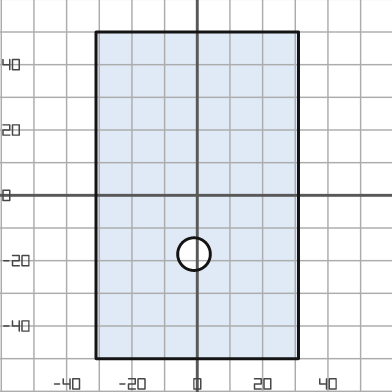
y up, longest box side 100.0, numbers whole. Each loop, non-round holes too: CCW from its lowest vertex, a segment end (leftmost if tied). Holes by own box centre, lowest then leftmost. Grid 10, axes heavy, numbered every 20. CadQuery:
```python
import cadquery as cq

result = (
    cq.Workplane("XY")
    .moveTo(-31.0, -50.0)
    .lineTo(31.0, -50.0)
    .lineTo(31.0, 50.0)
    .lineTo(-31.0, 50.0)
    .close()
    .moveTo(-1.0, -18.0)
    .circle(5.0)
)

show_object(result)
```